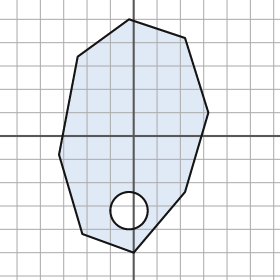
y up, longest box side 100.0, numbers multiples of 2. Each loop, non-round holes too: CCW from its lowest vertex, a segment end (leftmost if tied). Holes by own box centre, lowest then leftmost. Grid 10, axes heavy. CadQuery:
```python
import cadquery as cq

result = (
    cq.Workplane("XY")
    .moveTo(0.0, -50.0)
    .lineTo(22.0, -24.0)
    .lineTo(32.0, 10.0)
    .lineTo(22.0, 42.0)
    .lineTo(-2.0, 50.0)
    .lineTo(-24.0, 34.0)
    .lineTo(-32.0, -8.0)
    .lineTo(-22.0, -42.0)
    .close()
    .moveTo(-2.0, -32.0)
    .circle(8.0)
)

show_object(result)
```